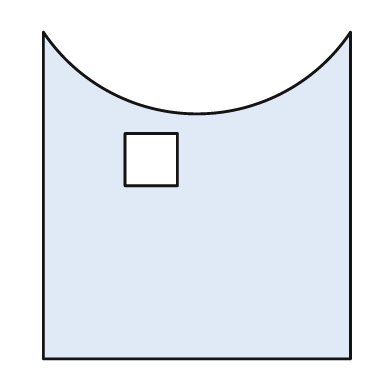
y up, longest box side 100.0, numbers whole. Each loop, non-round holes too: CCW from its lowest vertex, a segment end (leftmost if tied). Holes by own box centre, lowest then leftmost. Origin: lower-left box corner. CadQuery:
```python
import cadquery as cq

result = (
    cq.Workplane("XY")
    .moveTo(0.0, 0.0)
    .lineTo(94.0, 0.0)
    .lineTo(94.0, 100.0)
    .threePointArc((47.0, 75.0), (0.0, 100.0))
    .close()
    .moveTo(25.0, 53.0)
    .lineTo(41.0, 53.0)
    .lineTo(41.0, 69.0)
    .lineTo(25.0, 69.0)
    .close()
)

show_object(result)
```